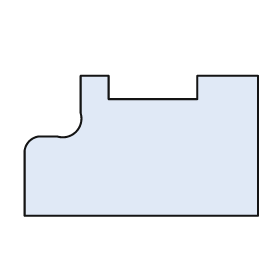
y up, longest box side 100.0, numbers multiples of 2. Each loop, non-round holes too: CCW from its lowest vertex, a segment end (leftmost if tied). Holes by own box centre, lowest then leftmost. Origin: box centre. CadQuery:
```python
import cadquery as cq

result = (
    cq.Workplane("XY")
    .moveTo(-50.0, -30.0)
    .lineTo(50.0, -30.0)
    .lineTo(50.0, 30.0)
    .lineTo(24.0, 30.0)
    .lineTo(24.0, 20.0)
    .lineTo(-14.0, 20.0)
    .lineTo(-14.0, 30.0)
    .lineTo(-26.0, 30.0)
    .lineTo(-26.0, 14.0)
    .threePointArc((-28.0, 6.0), (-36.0, 4.0))
    .lineTo(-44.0, 4.0)
    .threePointArc((-48.0, 2.0), (-50.0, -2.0))
    .close()
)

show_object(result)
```